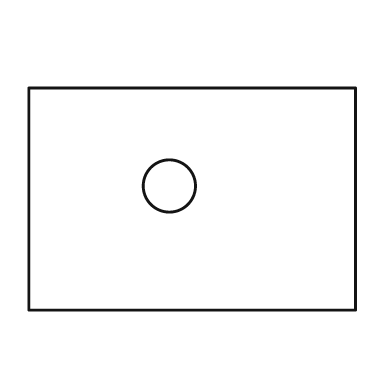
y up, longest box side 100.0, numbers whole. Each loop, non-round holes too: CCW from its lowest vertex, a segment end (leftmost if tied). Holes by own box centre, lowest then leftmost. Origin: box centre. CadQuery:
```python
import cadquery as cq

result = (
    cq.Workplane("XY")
    .moveTo(-50.0, -34.0)
    .lineTo(50.0, -34.0)
    .lineTo(50.0, 34.0)
    .lineTo(-50.0, 34.0)
    .close()
    .moveTo(-7.0, 4.0)
    .circle(8.0)
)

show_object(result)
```